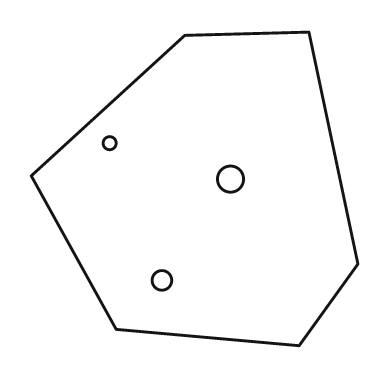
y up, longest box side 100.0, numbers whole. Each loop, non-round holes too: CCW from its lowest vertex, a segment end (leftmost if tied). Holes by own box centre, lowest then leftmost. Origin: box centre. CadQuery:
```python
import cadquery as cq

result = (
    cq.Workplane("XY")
    .moveTo(32.0, -48.0)
    .lineTo(50.0, -23.0)
    .lineTo(35.0, 48.0)
    .lineTo(-3.0, 47.0)
    .lineTo(-50.0, 4.0)
    .lineTo(-24.0, -43.0)
    .close()
    .moveTo(-10.0, -28.0)
    .circle(3.0)
    .moveTo(11.0, 3.0)
    .circle(4.0)
    .moveTo(-26.0, 14.0)
    .circle(2.0)
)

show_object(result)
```